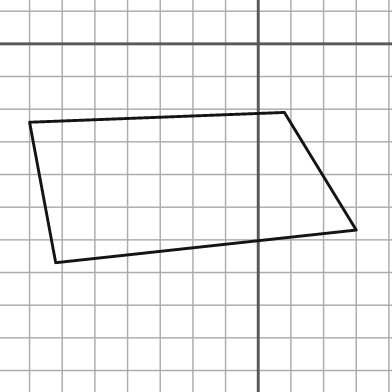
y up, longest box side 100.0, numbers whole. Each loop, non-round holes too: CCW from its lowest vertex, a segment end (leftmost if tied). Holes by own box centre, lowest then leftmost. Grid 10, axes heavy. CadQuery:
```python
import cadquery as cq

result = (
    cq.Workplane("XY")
    .moveTo(-62.0, -67.0)
    .lineTo(30.0, -57.0)
    .lineTo(8.0, -21.0)
    .lineTo(-70.0, -24.0)
    .close()
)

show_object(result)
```